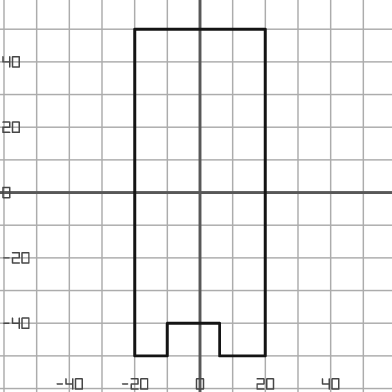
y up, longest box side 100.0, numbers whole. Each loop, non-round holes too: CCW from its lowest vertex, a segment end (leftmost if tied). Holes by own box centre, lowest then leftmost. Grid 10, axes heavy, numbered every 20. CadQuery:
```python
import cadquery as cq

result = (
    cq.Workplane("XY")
    .moveTo(-20.0, -50.0)
    .lineTo(-10.0, -50.0)
    .lineTo(-10.0, -40.0)
    .lineTo(6.0, -40.0)
    .lineTo(6.0, -50.0)
    .lineTo(20.0, -50.0)
    .lineTo(20.0, 50.0)
    .lineTo(-20.0, 50.0)
    .close()
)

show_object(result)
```